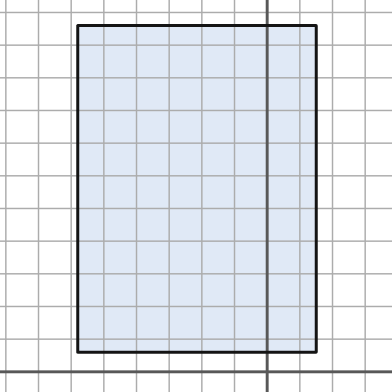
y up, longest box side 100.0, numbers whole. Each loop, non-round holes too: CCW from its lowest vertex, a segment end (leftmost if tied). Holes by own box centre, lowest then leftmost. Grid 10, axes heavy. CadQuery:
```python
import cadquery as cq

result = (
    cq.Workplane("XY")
    .moveTo(-58.0, 6.0)
    .lineTo(15.0, 6.0)
    .lineTo(15.0, 106.0)
    .lineTo(-58.0, 106.0)
    .close()
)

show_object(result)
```